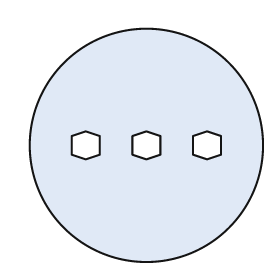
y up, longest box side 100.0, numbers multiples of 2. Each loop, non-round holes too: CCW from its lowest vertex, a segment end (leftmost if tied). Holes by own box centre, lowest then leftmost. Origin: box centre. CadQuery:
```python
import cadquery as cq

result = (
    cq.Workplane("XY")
    .moveTo(0.0, 0.0)
    .circle(50.0)
    .moveTo(-26.0, -6.0)
    .lineTo(-20.0, -4.0)
    .lineTo(-20.0, 4.0)
    .lineTo(-26.0, 6.0)
    .lineTo(-32.0, 4.0)
    .lineTo(-32.0, -4.0)
    .close()
    .moveTo(0.0, -6.0)
    .lineTo(6.0, -4.0)
    .lineTo(6.0, 4.0)
    .lineTo(0.0, 6.0)
    .lineTo(-6.0, 4.0)
    .lineTo(-6.0, -4.0)
    .close()
    .moveTo(26.0, -6.0)
    .lineTo(32.0, -4.0)
    .lineTo(32.0, 4.0)
    .lineTo(26.0, 6.0)
    .lineTo(20.0, 4.0)
    .lineTo(20.0, -4.0)
    .close()
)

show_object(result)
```